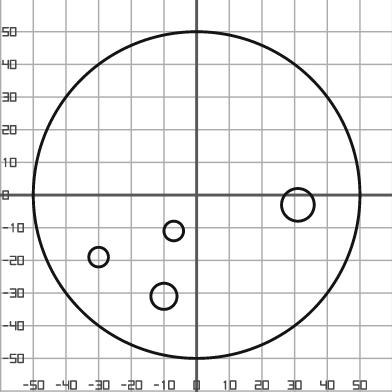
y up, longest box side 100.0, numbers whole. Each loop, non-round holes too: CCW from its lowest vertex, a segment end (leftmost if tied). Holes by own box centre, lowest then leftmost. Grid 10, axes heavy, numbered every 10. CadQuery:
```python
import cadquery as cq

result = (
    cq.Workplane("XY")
    .moveTo(0.0, 0.0)
    .circle(50.0)
    .moveTo(-10.0, -31.0)
    .circle(4.0)
    .moveTo(-30.0, -19.0)
    .circle(3.0)
    .moveTo(-7.0, -11.0)
    .circle(3.0)
    .moveTo(31.0, -3.0)
    .circle(5.0)
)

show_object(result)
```